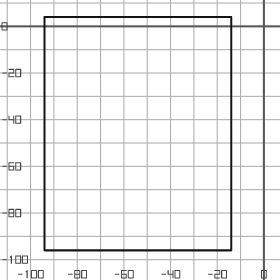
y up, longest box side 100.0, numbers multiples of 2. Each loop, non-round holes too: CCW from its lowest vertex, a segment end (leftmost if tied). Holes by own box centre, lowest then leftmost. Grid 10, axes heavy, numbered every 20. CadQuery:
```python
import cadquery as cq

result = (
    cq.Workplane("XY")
    .moveTo(-94.0, -96.0)
    .lineTo(-14.0, -96.0)
    .lineTo(-14.0, 4.0)
    .lineTo(-94.0, 4.0)
    .close()
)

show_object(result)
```